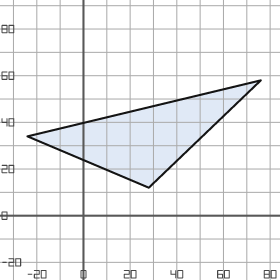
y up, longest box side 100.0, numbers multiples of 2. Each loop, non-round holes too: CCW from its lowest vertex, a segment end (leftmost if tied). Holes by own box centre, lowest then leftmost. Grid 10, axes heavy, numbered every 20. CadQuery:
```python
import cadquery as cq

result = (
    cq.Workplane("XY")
    .moveTo(28.0, 12.0)
    .lineTo(76.0, 58.0)
    .lineTo(-24.0, 34.0)
    .close()
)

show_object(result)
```